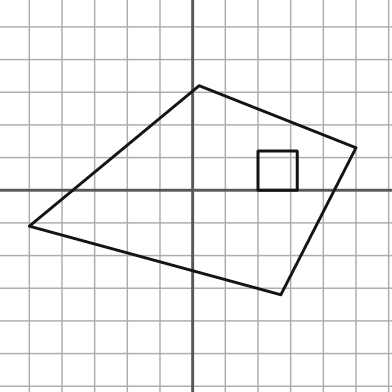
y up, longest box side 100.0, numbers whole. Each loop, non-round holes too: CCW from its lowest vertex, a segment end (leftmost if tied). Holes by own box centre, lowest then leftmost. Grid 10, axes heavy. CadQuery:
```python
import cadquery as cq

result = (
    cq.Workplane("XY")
    .moveTo(27.0, -32.0)
    .lineTo(50.0, 13.0)
    .lineTo(2.0, 32.0)
    .lineTo(-50.0, -11.0)
    .close()
    .moveTo(20.0, 0.0)
    .lineTo(32.0, 0.0)
    .lineTo(32.0, 12.0)
    .lineTo(20.0, 12.0)
    .close()
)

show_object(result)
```